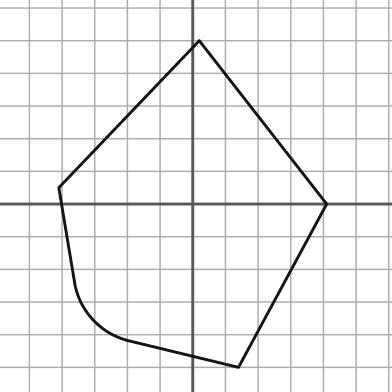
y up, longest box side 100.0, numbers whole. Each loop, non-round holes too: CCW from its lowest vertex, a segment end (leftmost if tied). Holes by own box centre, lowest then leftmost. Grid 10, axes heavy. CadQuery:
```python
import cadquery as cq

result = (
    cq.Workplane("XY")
    .moveTo(14.0, -50.0)
    .lineTo(41.0, 0.0)
    .lineTo(2.0, 50.0)
    .lineTo(-41.0, 5.0)
    .lineTo(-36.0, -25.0)
    .threePointArc((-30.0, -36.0), (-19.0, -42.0))
    .close()
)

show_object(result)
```